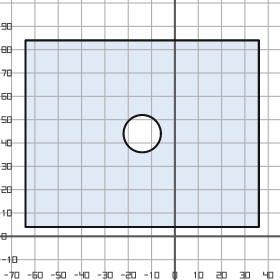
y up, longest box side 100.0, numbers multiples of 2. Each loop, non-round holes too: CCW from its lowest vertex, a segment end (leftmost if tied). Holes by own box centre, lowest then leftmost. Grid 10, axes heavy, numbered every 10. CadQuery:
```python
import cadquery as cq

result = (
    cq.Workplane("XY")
    .moveTo(-64.0, 4.0)
    .lineTo(36.0, 4.0)
    .lineTo(36.0, 84.0)
    .lineTo(-64.0, 84.0)
    .close()
    .moveTo(-14.0, 44.0)
    .circle(8.0)
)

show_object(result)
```